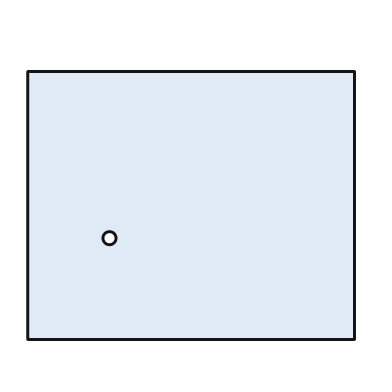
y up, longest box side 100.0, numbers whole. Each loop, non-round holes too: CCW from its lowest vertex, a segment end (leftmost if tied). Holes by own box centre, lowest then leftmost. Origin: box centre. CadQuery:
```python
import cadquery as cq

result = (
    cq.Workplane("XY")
    .moveTo(-50.0, -41.0)
    .lineTo(50.0, -41.0)
    .lineTo(50.0, 41.0)
    .lineTo(-50.0, 41.0)
    .close()
    .moveTo(-25.0, -10.0)
    .circle(2.0)
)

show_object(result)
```